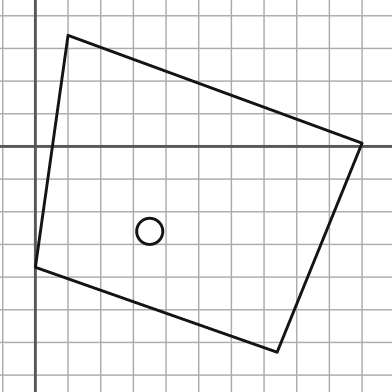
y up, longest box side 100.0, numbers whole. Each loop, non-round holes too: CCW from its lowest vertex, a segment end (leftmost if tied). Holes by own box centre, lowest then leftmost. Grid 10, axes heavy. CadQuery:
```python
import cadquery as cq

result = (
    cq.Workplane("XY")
    .moveTo(74.0, -63.0)
    .lineTo(100.0, 1.0)
    .lineTo(10.0, 34.0)
    .lineTo(0.0, -37.0)
    .close()
    .moveTo(35.0, -26.0)
    .circle(4.0)
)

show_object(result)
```